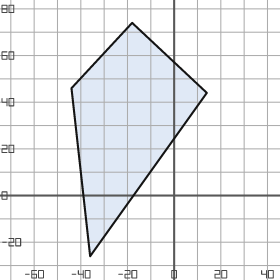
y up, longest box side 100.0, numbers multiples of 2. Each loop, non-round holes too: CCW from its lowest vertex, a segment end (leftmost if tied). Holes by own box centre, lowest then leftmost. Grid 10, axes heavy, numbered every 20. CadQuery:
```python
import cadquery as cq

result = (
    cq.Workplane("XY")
    .moveTo(-36.0, -26.0)
    .lineTo(14.0, 44.0)
    .lineTo(-18.0, 74.0)
    .lineTo(-44.0, 46.0)
    .close()
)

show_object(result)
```